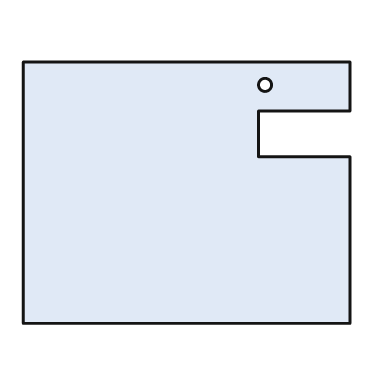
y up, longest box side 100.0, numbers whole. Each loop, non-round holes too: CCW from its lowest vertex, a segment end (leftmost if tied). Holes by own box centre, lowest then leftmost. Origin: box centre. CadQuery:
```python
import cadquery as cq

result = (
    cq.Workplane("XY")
    .moveTo(-50.0, -40.0)
    .lineTo(50.0, -40.0)
    .lineTo(50.0, 11.0)
    .lineTo(22.0, 11.0)
    .lineTo(22.0, 25.0)
    .lineTo(50.0, 25.0)
    .lineTo(50.0, 40.0)
    .lineTo(-50.0, 40.0)
    .close()
    .moveTo(24.0, 33.0)
    .circle(2.0)
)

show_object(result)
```